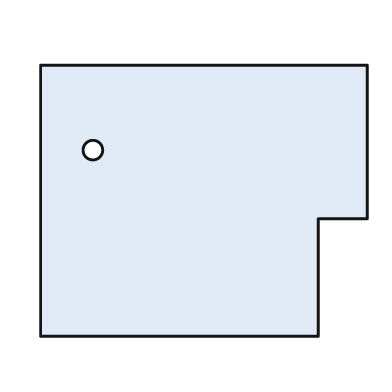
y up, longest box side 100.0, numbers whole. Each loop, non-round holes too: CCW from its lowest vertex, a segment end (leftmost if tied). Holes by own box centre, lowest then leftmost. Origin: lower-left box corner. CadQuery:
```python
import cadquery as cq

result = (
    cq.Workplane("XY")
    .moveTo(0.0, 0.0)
    .lineTo(85.0, 0.0)
    .lineTo(85.0, 36.0)
    .lineTo(100.0, 36.0)
    .lineTo(100.0, 83.0)
    .lineTo(0.0, 83.0)
    .close()
    .moveTo(16.0, 57.0)
    .circle(3.0)
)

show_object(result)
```